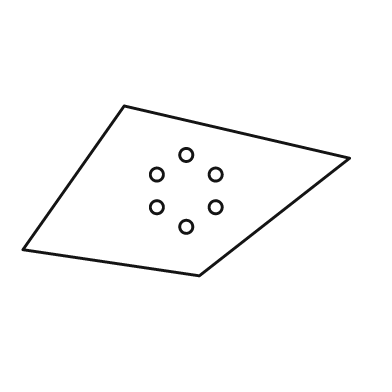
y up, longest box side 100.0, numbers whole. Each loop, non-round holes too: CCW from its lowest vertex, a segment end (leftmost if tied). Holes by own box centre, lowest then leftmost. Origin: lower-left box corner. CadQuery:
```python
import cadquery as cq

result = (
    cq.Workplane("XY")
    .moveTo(54.0, 0.0)
    .lineTo(100.0, 36.0)
    .lineTo(31.0, 52.0)
    .lineTo(0.0, 8.0)
    .close()
    .moveTo(50.0, 15.0)
    .circle(2.0)
    .moveTo(41.0, 21.0)
    .circle(2.0)
    .moveTo(59.0, 21.0)
    .circle(2.0)
    .moveTo(41.0, 31.0)
    .circle(2.0)
    .moveTo(59.0, 31.0)
    .circle(2.0)
    .moveTo(50.0, 37.0)
    .circle(2.0)
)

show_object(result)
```